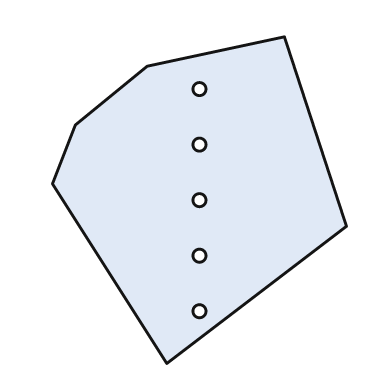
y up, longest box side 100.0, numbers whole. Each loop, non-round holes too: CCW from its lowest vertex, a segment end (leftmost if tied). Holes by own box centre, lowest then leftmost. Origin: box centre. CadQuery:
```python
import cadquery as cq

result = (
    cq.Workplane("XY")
    .moveTo(-10.0, -50.0)
    .lineTo(45.0, -8.0)
    .lineTo(26.0, 50.0)
    .lineTo(-16.0, 41.0)
    .lineTo(-38.0, 23.0)
    .lineTo(-45.0, 5.0)
    .close()
    .moveTo(0.0, -34.0)
    .circle(2.0)
    .moveTo(0.0, -17.0)
    .circle(2.0)
    .moveTo(0.0, 0.0)
    .circle(2.0)
    .moveTo(0.0, 17.0)
    .circle(2.0)
    .moveTo(0.0, 34.0)
    .circle(2.0)
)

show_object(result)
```